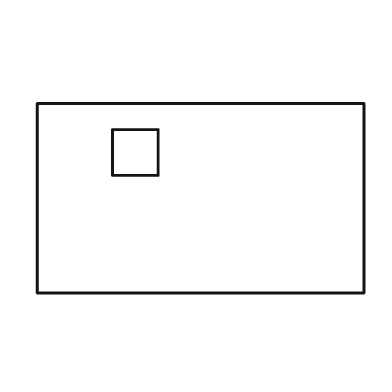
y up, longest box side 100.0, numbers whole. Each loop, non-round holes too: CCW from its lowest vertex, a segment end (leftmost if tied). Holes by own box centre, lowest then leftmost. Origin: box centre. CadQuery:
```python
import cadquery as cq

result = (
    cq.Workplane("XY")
    .moveTo(-50.0, -29.0)
    .lineTo(50.0, -29.0)
    .lineTo(50.0, 29.0)
    .lineTo(-50.0, 29.0)
    .close()
    .moveTo(-27.0, 7.0)
    .lineTo(-13.0, 7.0)
    .lineTo(-13.0, 21.0)
    .lineTo(-27.0, 21.0)
    .close()
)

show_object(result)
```